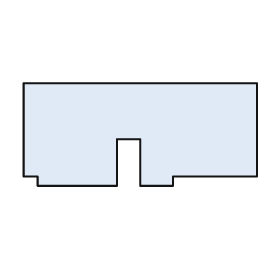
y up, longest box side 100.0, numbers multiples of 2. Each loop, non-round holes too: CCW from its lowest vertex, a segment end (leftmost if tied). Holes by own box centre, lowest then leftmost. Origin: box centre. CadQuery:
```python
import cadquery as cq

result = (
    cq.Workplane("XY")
    .moveTo(-44.0, -22.0)
    .lineTo(-10.0, -22.0)
    .lineTo(-10.0, -2.0)
    .lineTo(0.0, -2.0)
    .lineTo(0.0, -22.0)
    .lineTo(14.0, -22.0)
    .lineTo(14.0, -18.0)
    .lineTo(50.0, -18.0)
    .lineTo(50.0, 22.0)
    .lineTo(-50.0, 22.0)
    .lineTo(-50.0, -18.0)
    .lineTo(-44.0, -18.0)
    .close()
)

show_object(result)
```